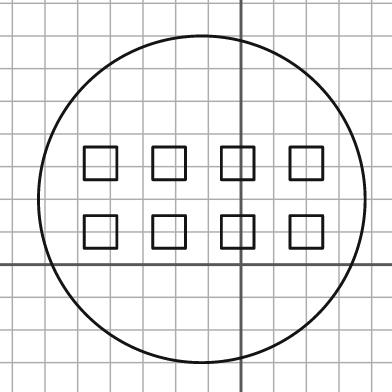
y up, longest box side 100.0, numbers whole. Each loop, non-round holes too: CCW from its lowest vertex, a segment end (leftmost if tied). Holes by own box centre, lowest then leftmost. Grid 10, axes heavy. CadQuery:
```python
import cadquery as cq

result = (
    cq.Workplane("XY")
    .moveTo(-12.0, 20.0)
    .circle(50.0)
    .moveTo(-48.0, 5.0)
    .lineTo(-38.0, 5.0)
    .lineTo(-38.0, 15.0)
    .lineTo(-48.0, 15.0)
    .close()
    .moveTo(-27.0, 5.0)
    .lineTo(-17.0, 5.0)
    .lineTo(-17.0, 15.0)
    .lineTo(-27.0, 15.0)
    .close()
    .moveTo(-6.0, 5.0)
    .lineTo(4.0, 5.0)
    .lineTo(4.0, 15.0)
    .lineTo(-6.0, 15.0)
    .close()
    .moveTo(15.0, 5.0)
    .lineTo(25.0, 5.0)
    .lineTo(25.0, 15.0)
    .lineTo(15.0, 15.0)
    .close()
    .moveTo(-48.0, 26.0)
    .lineTo(-38.0, 26.0)
    .lineTo(-38.0, 36.0)
    .lineTo(-48.0, 36.0)
    .close()
    .moveTo(-27.0, 26.0)
    .lineTo(-17.0, 26.0)
    .lineTo(-17.0, 36.0)
    .lineTo(-27.0, 36.0)
    .close()
    .moveTo(-6.0, 26.0)
    .lineTo(4.0, 26.0)
    .lineTo(4.0, 36.0)
    .lineTo(-6.0, 36.0)
    .close()
    .moveTo(15.0, 26.0)
    .lineTo(25.0, 26.0)
    .lineTo(25.0, 36.0)
    .lineTo(15.0, 36.0)
    .close()
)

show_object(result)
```